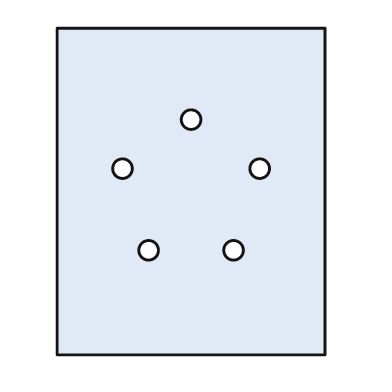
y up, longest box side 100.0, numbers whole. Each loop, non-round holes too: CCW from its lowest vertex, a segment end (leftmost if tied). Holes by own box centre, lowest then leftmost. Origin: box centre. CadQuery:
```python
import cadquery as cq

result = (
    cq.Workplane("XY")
    .moveTo(-41.0, -50.0)
    .lineTo(41.0, -50.0)
    .lineTo(41.0, 50.0)
    .lineTo(-41.0, 50.0)
    .close()
    .moveTo(-13.0, -18.0)
    .circle(3.0)
    .moveTo(13.0, -18.0)
    .circle(3.0)
    .moveTo(-21.0, 7.0)
    .circle(3.0)
    .moveTo(21.0, 7.0)
    .circle(3.0)
    .moveTo(0.0, 22.0)
    .circle(3.0)
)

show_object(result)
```